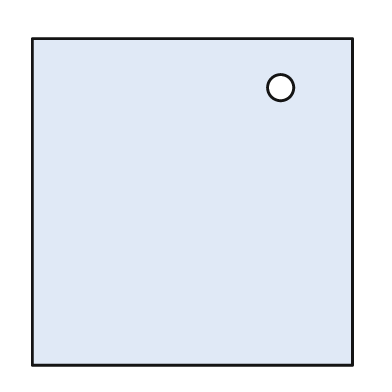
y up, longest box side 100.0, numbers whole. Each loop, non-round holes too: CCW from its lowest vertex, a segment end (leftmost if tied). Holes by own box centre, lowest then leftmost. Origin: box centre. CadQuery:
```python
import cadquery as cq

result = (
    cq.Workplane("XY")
    .moveTo(-49.0, -50.0)
    .lineTo(49.0, -50.0)
    .lineTo(49.0, 50.0)
    .lineTo(-49.0, 50.0)
    .close()
    .moveTo(27.0, 35.0)
    .circle(4.0)
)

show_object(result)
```